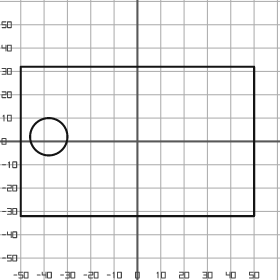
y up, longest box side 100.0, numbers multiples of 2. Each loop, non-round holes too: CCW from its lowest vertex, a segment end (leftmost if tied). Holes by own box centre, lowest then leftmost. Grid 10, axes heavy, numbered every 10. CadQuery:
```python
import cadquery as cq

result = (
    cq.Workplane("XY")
    .moveTo(-50.0, -32.0)
    .lineTo(50.0, -32.0)
    .lineTo(50.0, 32.0)
    .lineTo(-50.0, 32.0)
    .close()
    .moveTo(-38.0, 2.0)
    .circle(8.0)
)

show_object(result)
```